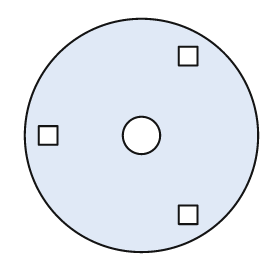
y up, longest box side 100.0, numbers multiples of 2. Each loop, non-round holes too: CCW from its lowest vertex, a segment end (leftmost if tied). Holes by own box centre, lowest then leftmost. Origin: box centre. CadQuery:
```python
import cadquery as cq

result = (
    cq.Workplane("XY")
    .moveTo(0.0, 0.0)
    .circle(50.0)
    .moveTo(16.0, -38.0)
    .lineTo(24.0, -38.0)
    .lineTo(24.0, -30.0)
    .lineTo(16.0, -30.0)
    .close()
    .moveTo(-44.0, -4.0)
    .lineTo(-36.0, -4.0)
    .lineTo(-36.0, 4.0)
    .lineTo(-44.0, 4.0)
    .close()
    .moveTo(0.0, 0.0)
    .circle(8.0)
    .moveTo(16.0, 30.0)
    .lineTo(24.0, 30.0)
    .lineTo(24.0, 38.0)
    .lineTo(16.0, 38.0)
    .close()
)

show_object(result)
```